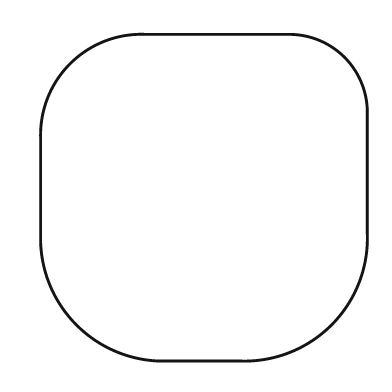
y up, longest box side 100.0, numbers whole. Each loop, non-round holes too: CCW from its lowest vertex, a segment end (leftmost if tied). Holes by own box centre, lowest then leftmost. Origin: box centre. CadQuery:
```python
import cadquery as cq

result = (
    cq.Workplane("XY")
    .moveTo(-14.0, -50.0)
    .lineTo(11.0, -50.0)
    .threePointArc((39.0, -39.0), (50.0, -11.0))
    .lineTo(50.0, 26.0)
    .threePointArc((43.0, 43.0), (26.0, 50.0))
    .lineTo(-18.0, 50.0)
    .threePointArc((-41.0, 41.0), (-50.0, 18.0))
    .lineTo(-50.0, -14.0)
    .threePointArc((-39.0, -39.0), (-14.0, -50.0))
    .close()
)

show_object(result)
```